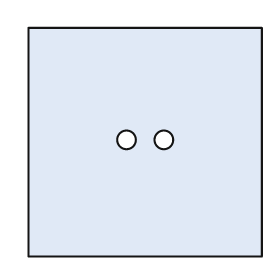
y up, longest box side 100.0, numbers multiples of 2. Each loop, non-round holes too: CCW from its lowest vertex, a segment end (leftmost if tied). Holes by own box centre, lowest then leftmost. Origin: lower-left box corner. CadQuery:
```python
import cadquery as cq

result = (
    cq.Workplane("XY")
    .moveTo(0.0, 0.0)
    .lineTo(100.0, 0.0)
    .lineTo(100.0, 98.0)
    .lineTo(0.0, 98.0)
    .close()
    .moveTo(42.0, 50.0)
    .circle(4.0)
    .moveTo(58.0, 50.0)
    .circle(4.0)
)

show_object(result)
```